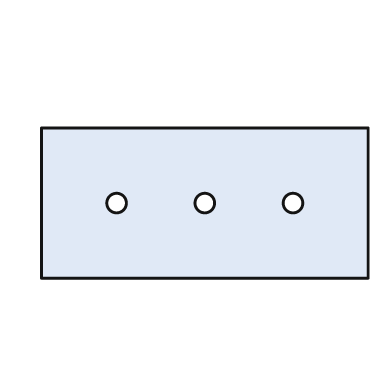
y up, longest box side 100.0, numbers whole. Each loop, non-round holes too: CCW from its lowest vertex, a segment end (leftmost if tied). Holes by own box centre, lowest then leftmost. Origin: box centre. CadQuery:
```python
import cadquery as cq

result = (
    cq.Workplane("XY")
    .moveTo(-50.0, -23.0)
    .lineTo(50.0, -23.0)
    .lineTo(50.0, 23.0)
    .lineTo(-50.0, 23.0)
    .close()
    .moveTo(-27.0, 0.0)
    .circle(3.0)
    .moveTo(0.0, 0.0)
    .circle(3.0)
    .moveTo(27.0, 0.0)
    .circle(3.0)
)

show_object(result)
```